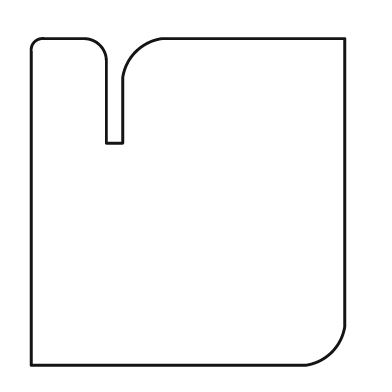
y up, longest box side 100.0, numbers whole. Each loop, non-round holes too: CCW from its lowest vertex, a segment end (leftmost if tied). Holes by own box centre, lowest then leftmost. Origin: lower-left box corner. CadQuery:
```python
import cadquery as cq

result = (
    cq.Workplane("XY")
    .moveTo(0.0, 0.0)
    .lineTo(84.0, 0.0)
    .threePointArc((92.0, 4.0), (96.0, 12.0))
    .lineTo(96.0, 100.0)
    .lineTo(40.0, 100.0)
    .threePointArc((32.0, 96.0), (28.0, 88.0))
    .lineTo(28.0, 68.0)
    .lineTo(23.0, 68.0)
    .lineTo(23.0, 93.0)
    .threePointArc((21.0, 98.0), (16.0, 100.0))
    .lineTo(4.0, 100.0)
    .threePointArc((1.0, 99.0), (0.0, 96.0))
    .close()
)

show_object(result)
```